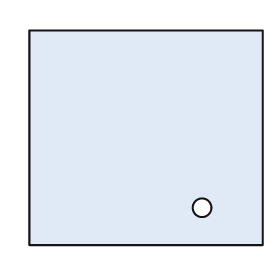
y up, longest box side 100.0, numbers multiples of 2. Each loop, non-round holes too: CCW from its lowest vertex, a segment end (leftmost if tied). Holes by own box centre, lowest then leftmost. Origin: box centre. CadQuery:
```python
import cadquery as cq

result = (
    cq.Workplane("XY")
    .moveTo(-50.0, -46.0)
    .lineTo(50.0, -46.0)
    .lineTo(50.0, 46.0)
    .lineTo(-50.0, 46.0)
    .close()
    .moveTo(24.0, -30.0)
    .circle(4.0)
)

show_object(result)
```